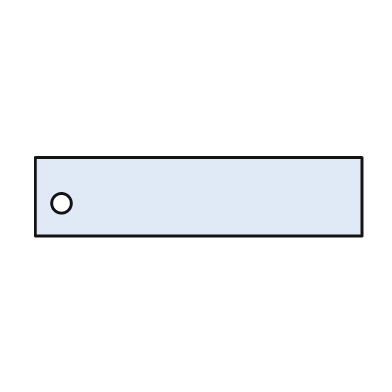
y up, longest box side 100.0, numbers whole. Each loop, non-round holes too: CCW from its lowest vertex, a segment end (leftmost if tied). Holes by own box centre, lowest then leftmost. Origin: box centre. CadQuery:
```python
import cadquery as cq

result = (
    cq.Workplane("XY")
    .moveTo(-50.0, -12.0)
    .lineTo(50.0, -12.0)
    .lineTo(50.0, 12.0)
    .lineTo(-50.0, 12.0)
    .close()
    .moveTo(-42.0, -2.0)
    .circle(3.0)
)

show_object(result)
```